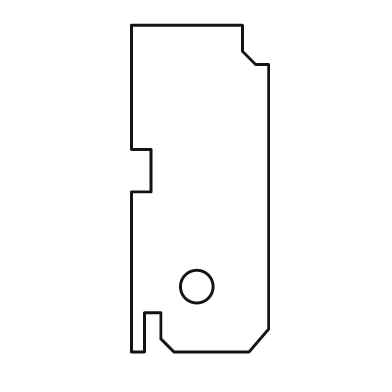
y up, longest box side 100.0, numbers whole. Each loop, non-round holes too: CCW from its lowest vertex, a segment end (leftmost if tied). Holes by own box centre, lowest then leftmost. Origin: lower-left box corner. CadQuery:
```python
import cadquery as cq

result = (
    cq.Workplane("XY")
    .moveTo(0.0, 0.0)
    .lineTo(4.0, 0.0)
    .lineTo(4.0, 12.0)
    .lineTo(9.0, 12.0)
    .lineTo(9.0, 4.0)
    .lineTo(13.0, 0.0)
    .lineTo(36.0, 0.0)
    .lineTo(42.0, 7.0)
    .lineTo(42.0, 88.0)
    .lineTo(38.0, 88.0)
    .lineTo(34.0, 92.0)
    .lineTo(34.0, 100.0)
    .lineTo(0.0, 100.0)
    .lineTo(0.0, 62.0)
    .lineTo(6.0, 62.0)
    .lineTo(6.0, 49.0)
    .lineTo(0.0, 49.0)
    .close()
    .moveTo(20.0, 20.0)
    .circle(5.0)
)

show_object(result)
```